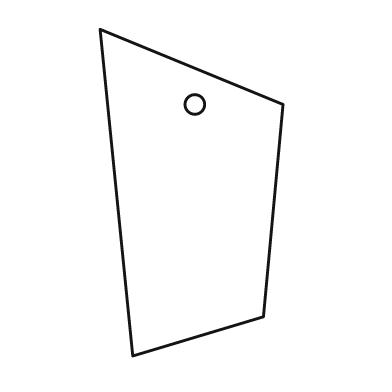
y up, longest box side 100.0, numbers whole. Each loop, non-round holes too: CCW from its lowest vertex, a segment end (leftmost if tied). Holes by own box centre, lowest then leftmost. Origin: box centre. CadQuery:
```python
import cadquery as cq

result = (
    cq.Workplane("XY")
    .moveTo(-18.0, -50.0)
    .lineTo(22.0, -38.0)
    .lineTo(28.0, 27.0)
    .lineTo(-28.0, 50.0)
    .close()
    .moveTo(1.0, 27.0)
    .circle(3.0)
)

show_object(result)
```